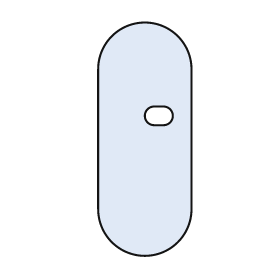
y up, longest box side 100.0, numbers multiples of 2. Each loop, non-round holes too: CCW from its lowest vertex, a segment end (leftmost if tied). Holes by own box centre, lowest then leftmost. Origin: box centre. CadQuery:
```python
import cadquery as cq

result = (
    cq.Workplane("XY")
    .moveTo(-20.0, -30.0)
    .threePointArc((0.0, -50.0), (20.0, -30.0))
    .lineTo(20.0, 30.0)
    .threePointArc((0.0, 50.0), (-20.0, 30.0))
    .close()
    .moveTo(4.0, 6.0)
    .lineTo(8.0, 6.0)
    .threePointArc((12.0, 10.0), (8.0, 14.0))
    .lineTo(4.0, 14.0)
    .threePointArc((0.0, 10.0), (4.0, 6.0))
    .close()
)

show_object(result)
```